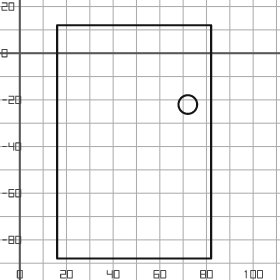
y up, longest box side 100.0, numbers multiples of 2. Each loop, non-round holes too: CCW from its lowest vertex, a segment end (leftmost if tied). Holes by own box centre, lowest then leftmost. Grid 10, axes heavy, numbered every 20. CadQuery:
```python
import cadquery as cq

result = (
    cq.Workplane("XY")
    .moveTo(16.0, -88.0)
    .lineTo(82.0, -88.0)
    .lineTo(82.0, 12.0)
    .lineTo(16.0, 12.0)
    .close()
    .moveTo(72.0, -22.0)
    .circle(4.0)
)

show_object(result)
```